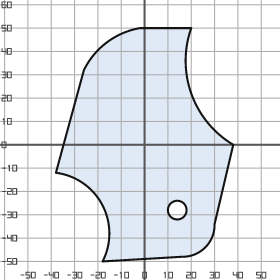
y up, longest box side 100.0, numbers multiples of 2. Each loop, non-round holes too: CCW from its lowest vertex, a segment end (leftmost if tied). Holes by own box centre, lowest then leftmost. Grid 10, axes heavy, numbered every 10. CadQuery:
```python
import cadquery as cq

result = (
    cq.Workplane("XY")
    .moveTo(-18.0, -50.0)
    .lineTo(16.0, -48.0)
    .threePointArc((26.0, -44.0), (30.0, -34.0))
    .lineTo(38.0, 0.0)
    .threePointArc((20.0, 22.0), (20.0, 50.0))
    .lineTo(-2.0, 50.0)
    .threePointArc((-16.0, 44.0), (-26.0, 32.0))
    .lineTo(-38.0, -12.0)
    .threePointArc((-18.0, -26.0), (-18.0, -50.0))
    .close()
    .moveTo(14.0, -28.0)
    .circle(4.0)
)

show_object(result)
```